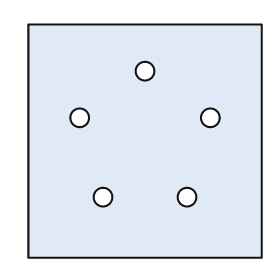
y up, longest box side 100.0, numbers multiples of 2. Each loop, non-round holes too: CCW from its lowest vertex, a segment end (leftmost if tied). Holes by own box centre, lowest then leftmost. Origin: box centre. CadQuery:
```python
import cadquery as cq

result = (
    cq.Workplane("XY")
    .moveTo(-50.0, -50.0)
    .lineTo(50.0, -50.0)
    .lineTo(50.0, 50.0)
    .lineTo(-50.0, 50.0)
    .close()
    .moveTo(-18.0, -24.0)
    .circle(4.0)
    .moveTo(18.0, -24.0)
    .circle(4.0)
    .moveTo(-28.0, 10.0)
    .circle(4.0)
    .moveTo(28.0, 10.0)
    .circle(4.0)
    .moveTo(0.0, 30.0)
    .circle(4.0)
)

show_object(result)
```